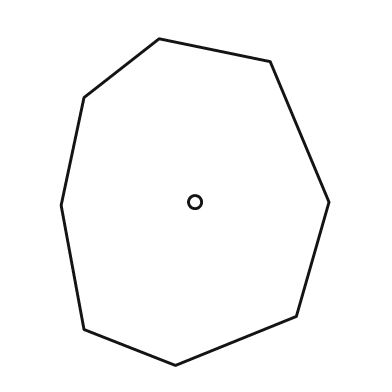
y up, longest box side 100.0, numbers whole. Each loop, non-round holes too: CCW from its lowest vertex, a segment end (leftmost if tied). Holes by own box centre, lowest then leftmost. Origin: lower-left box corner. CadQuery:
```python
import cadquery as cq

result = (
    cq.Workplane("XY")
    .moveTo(35.0, 0.0)
    .lineTo(72.0, 15.0)
    .lineTo(82.0, 50.0)
    .lineTo(64.0, 93.0)
    .lineTo(30.0, 100.0)
    .lineTo(7.0, 82.0)
    .lineTo(0.0, 49.0)
    .lineTo(7.0, 11.0)
    .close()
    .moveTo(41.0, 50.0)
    .circle(2.0)
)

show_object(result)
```